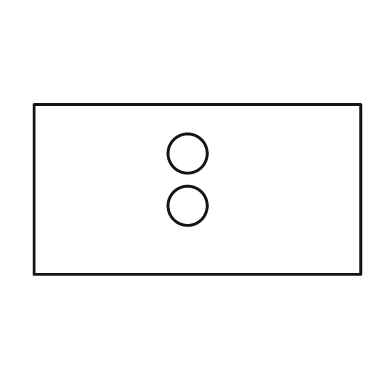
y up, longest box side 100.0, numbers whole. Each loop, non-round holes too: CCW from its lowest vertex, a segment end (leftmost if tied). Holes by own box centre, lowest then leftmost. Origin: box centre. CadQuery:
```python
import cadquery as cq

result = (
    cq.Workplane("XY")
    .moveTo(-50.0, -26.0)
    .lineTo(50.0, -26.0)
    .lineTo(50.0, 26.0)
    .lineTo(-50.0, 26.0)
    .close()
    .moveTo(-3.0, -5.0)
    .circle(6.0)
    .moveTo(-3.0, 11.0)
    .circle(6.0)
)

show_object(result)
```